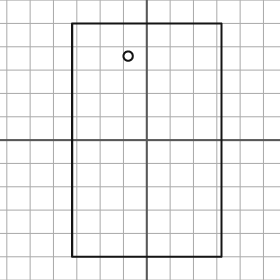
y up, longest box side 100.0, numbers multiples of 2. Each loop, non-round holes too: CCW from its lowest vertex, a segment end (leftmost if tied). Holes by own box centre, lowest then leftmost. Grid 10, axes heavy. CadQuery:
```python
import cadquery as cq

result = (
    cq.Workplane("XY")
    .moveTo(-32.0, -50.0)
    .lineTo(32.0, -50.0)
    .lineTo(32.0, 50.0)
    .lineTo(-32.0, 50.0)
    .close()
    .moveTo(-8.0, 36.0)
    .circle(2.0)
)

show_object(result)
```